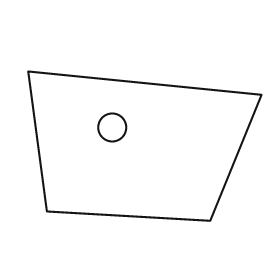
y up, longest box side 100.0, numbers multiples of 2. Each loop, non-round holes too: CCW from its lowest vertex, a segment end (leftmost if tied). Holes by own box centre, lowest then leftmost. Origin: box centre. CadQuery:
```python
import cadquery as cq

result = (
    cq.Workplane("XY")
    .moveTo(28.0, -32.0)
    .lineTo(50.0, 22.0)
    .lineTo(-50.0, 32.0)
    .lineTo(-42.0, -28.0)
    .close()
    .moveTo(-14.0, 8.0)
    .circle(6.0)
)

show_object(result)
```